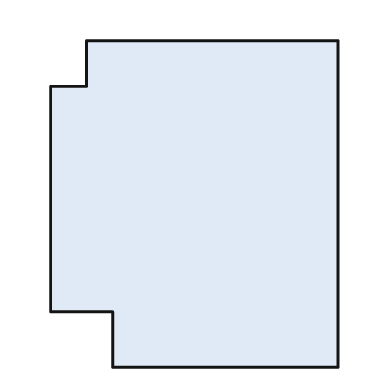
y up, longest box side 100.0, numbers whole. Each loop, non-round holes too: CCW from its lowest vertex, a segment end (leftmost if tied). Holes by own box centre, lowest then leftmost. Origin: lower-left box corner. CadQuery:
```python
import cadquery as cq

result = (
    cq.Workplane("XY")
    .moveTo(19.0, 0.0)
    .lineTo(88.0, 0.0)
    .lineTo(88.0, 100.0)
    .lineTo(11.0, 100.0)
    .lineTo(11.0, 86.0)
    .lineTo(0.0, 86.0)
    .lineTo(0.0, 17.0)
    .lineTo(19.0, 17.0)
    .close()
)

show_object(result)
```